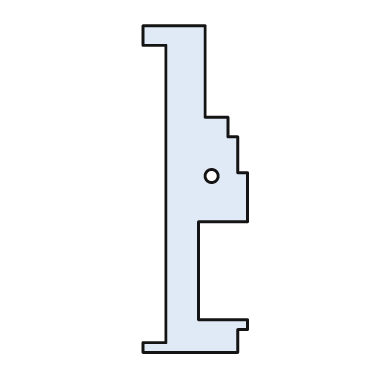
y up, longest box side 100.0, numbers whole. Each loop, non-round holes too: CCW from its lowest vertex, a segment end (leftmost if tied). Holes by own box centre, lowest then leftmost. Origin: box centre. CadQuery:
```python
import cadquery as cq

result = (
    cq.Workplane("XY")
    .moveTo(-16.0, -50.0)
    .lineTo(13.0, -50.0)
    .lineTo(13.0, -43.0)
    .lineTo(16.0, -43.0)
    .lineTo(16.0, -40.0)
    .lineTo(1.0, -40.0)
    .lineTo(1.0, -10.0)
    .lineTo(16.0, -10.0)
    .lineTo(16.0, 5.0)
    .lineTo(13.0, 5.0)
    .lineTo(13.0, 16.0)
    .lineTo(10.0, 16.0)
    .lineTo(10.0, 22.0)
    .lineTo(3.0, 22.0)
    .lineTo(3.0, 50.0)
    .lineTo(-16.0, 50.0)
    .lineTo(-16.0, 44.0)
    .lineTo(-9.0, 44.0)
    .lineTo(-9.0, -47.0)
    .lineTo(-16.0, -47.0)
    .close()
    .moveTo(5.0, 4.0)
    .circle(2.0)
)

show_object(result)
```